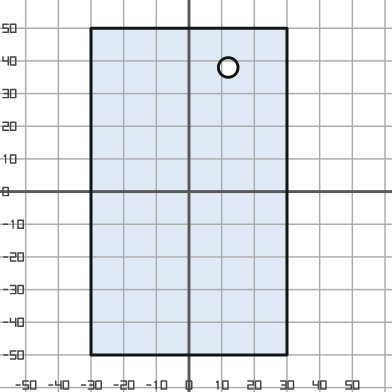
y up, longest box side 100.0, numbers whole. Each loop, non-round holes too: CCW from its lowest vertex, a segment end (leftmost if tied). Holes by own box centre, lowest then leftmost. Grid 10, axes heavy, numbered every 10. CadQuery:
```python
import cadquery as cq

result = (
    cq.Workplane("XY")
    .moveTo(-30.0, -50.0)
    .lineTo(30.0, -50.0)
    .lineTo(30.0, 50.0)
    .lineTo(-30.0, 50.0)
    .close()
    .moveTo(12.0, 38.0)
    .circle(3.0)
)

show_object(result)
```